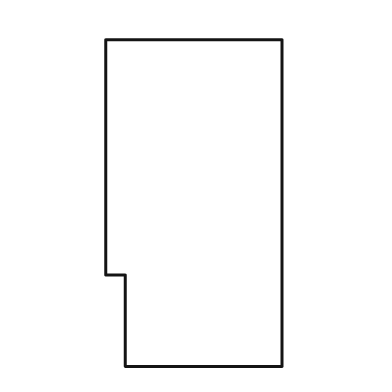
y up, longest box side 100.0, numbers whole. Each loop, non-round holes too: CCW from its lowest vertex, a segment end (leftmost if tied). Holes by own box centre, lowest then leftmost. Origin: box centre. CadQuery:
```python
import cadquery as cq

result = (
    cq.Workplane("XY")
    .moveTo(-21.0, -50.0)
    .lineTo(27.0, -50.0)
    .lineTo(27.0, 50.0)
    .lineTo(-27.0, 50.0)
    .lineTo(-27.0, -22.0)
    .lineTo(-21.0, -22.0)
    .close()
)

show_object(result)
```